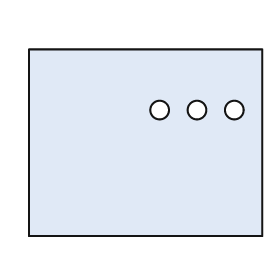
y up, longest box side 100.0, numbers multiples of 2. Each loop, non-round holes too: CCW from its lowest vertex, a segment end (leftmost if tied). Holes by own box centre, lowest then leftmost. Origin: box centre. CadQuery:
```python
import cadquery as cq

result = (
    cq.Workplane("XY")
    .moveTo(-50.0, -40.0)
    .lineTo(50.0, -40.0)
    .lineTo(50.0, 40.0)
    .lineTo(-50.0, 40.0)
    .close()
    .moveTo(6.0, 14.0)
    .circle(4.0)
    .moveTo(22.0, 14.0)
    .circle(4.0)
    .moveTo(38.0, 14.0)
    .circle(4.0)
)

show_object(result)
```